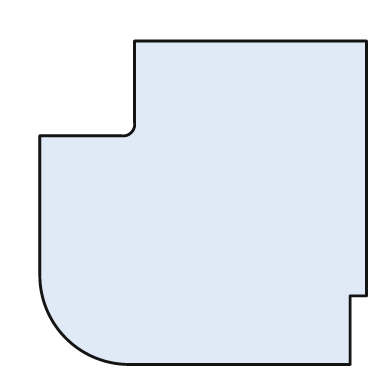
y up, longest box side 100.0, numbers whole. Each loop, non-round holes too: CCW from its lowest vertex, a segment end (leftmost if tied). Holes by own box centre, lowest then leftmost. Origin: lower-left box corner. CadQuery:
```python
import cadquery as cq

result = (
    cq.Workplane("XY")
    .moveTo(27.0, 0.0)
    .lineTo(95.0, 0.0)
    .lineTo(95.0, 21.0)
    .lineTo(100.0, 21.0)
    .lineTo(100.0, 99.0)
    .lineTo(29.0, 99.0)
    .lineTo(29.0, 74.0)
    .threePointArc((28.0, 71.0), (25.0, 70.0))
    .lineTo(0.0, 70.0)
    .lineTo(0.0, 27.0)
    .threePointArc((8.0, 8.0), (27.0, 0.0))
    .close()
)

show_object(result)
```